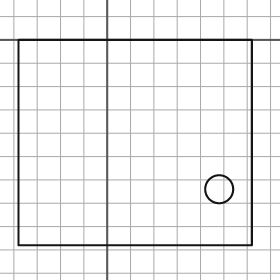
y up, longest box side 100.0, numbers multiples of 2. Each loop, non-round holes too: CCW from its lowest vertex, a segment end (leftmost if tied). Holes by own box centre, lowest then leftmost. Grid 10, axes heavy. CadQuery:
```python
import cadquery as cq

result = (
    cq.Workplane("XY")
    .moveTo(-38.0, -88.0)
    .lineTo(62.0, -88.0)
    .lineTo(62.0, 0.0)
    .lineTo(-38.0, 0.0)
    .close()
    .moveTo(48.0, -64.0)
    .circle(6.0)
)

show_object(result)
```